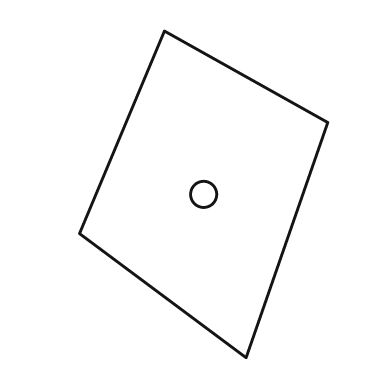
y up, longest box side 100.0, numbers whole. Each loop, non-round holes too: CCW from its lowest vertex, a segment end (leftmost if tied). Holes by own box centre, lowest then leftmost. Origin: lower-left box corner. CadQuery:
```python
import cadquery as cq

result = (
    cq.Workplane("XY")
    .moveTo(51.0, 0.0)
    .lineTo(76.0, 72.0)
    .lineTo(26.0, 100.0)
    .lineTo(0.0, 38.0)
    .close()
    .moveTo(38.0, 50.0)
    .circle(4.0)
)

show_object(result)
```